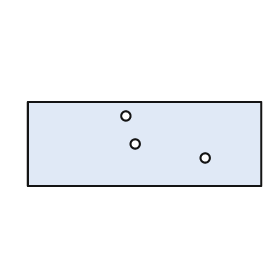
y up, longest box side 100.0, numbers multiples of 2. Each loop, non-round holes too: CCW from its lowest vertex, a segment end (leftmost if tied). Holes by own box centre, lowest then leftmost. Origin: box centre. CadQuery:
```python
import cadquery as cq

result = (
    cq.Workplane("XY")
    .moveTo(-50.0, -18.0)
    .lineTo(50.0, -18.0)
    .lineTo(50.0, 18.0)
    .lineTo(-50.0, 18.0)
    .close()
    .moveTo(26.0, -6.0)
    .circle(2.0)
    .moveTo(-4.0, 0.0)
    .circle(2.0)
    .moveTo(-8.0, 12.0)
    .circle(2.0)
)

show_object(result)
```